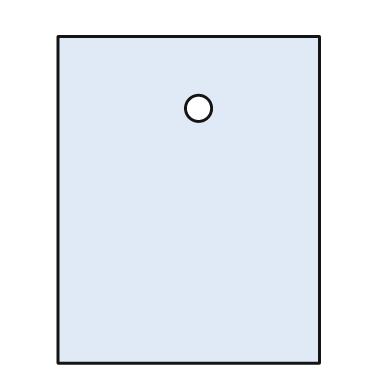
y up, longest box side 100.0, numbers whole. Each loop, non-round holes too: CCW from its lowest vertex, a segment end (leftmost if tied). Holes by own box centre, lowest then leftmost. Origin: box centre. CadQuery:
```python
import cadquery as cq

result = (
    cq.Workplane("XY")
    .moveTo(-40.0, -50.0)
    .lineTo(40.0, -50.0)
    .lineTo(40.0, 50.0)
    .lineTo(-40.0, 50.0)
    .close()
    .moveTo(3.0, 28.0)
    .circle(4.0)
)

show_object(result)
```